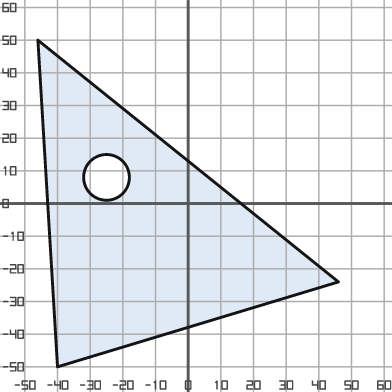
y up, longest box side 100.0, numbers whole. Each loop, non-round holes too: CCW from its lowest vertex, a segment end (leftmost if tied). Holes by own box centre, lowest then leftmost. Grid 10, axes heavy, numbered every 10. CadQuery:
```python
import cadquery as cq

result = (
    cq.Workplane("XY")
    .moveTo(-40.0, -50.0)
    .lineTo(46.0, -24.0)
    .lineTo(-46.0, 50.0)
    .close()
    .moveTo(-25.0, 8.0)
    .circle(7.0)
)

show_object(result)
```